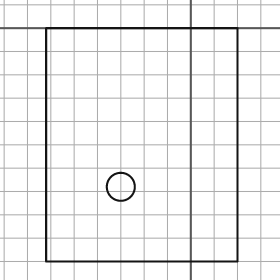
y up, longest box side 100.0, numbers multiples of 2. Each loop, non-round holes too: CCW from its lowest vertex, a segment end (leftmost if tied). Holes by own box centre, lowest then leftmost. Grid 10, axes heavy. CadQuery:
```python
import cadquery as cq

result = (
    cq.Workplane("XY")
    .moveTo(-62.0, -100.0)
    .lineTo(20.0, -100.0)
    .lineTo(20.0, 0.0)
    .lineTo(-62.0, 0.0)
    .close()
    .moveTo(-30.0, -68.0)
    .circle(6.0)
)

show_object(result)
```